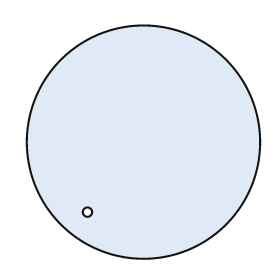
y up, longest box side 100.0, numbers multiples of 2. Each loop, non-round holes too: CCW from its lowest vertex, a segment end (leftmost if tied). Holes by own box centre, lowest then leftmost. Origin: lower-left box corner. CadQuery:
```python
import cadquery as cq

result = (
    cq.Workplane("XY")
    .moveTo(50.0, 50.0)
    .circle(50.0)
    .moveTo(26.0, 20.0)
    .circle(2.0)
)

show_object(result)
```